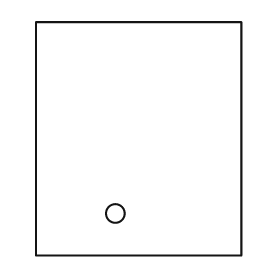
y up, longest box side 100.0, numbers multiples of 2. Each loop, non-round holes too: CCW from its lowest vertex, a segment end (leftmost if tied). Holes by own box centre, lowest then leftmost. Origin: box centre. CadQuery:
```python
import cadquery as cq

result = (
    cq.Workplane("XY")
    .moveTo(-44.0, -50.0)
    .lineTo(44.0, -50.0)
    .lineTo(44.0, 50.0)
    .lineTo(-44.0, 50.0)
    .close()
    .moveTo(-10.0, -32.0)
    .circle(4.0)
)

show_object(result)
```